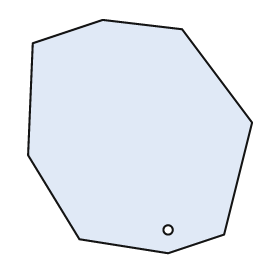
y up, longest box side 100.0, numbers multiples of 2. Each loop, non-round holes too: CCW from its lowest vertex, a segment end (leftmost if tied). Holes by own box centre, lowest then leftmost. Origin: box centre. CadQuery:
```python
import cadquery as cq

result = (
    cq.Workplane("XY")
    .moveTo(12.0, -50.0)
    .lineTo(36.0, -42.0)
    .lineTo(48.0, 6.0)
    .lineTo(18.0, 46.0)
    .lineTo(-16.0, 50.0)
    .lineTo(-46.0, 40.0)
    .lineTo(-48.0, -8.0)
    .lineTo(-26.0, -44.0)
    .close()
    .moveTo(12.0, -40.0)
    .circle(2.0)
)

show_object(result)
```